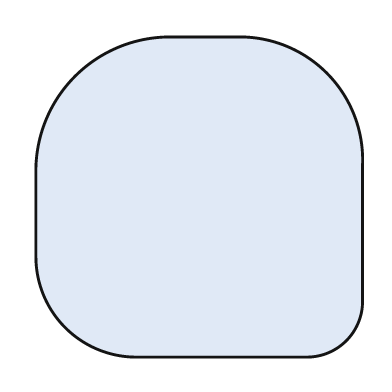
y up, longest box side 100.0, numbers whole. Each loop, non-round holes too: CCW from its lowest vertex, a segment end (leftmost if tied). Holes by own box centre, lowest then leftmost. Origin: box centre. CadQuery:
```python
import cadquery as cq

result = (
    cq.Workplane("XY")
    .moveTo(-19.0, -49.0)
    .lineTo(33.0, -49.0)
    .threePointArc((45.0, -44.0), (50.0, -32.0))
    .lineTo(50.0, 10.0)
    .threePointArc((39.0, 38.0), (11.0, 49.0))
    .lineTo(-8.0, 49.0)
    .threePointArc((-38.0, 37.0), (-50.0, 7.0))
    .lineTo(-50.0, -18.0)
    .threePointArc((-41.0, -40.0), (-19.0, -49.0))
    .close()
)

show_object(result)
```